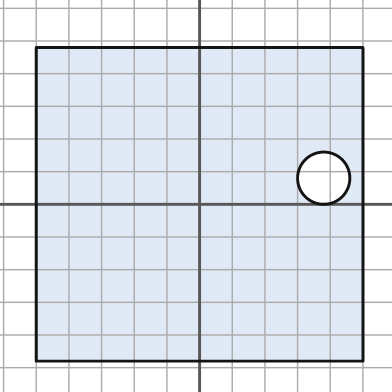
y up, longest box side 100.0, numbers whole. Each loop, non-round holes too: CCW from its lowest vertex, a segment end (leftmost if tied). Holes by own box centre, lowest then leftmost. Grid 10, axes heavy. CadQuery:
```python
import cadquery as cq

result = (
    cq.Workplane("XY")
    .moveTo(-50.0, -48.0)
    .lineTo(50.0, -48.0)
    .lineTo(50.0, 48.0)
    .lineTo(-50.0, 48.0)
    .close()
    .moveTo(38.0, 8.0)
    .circle(8.0)
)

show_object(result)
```